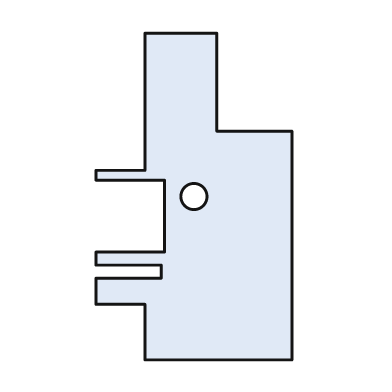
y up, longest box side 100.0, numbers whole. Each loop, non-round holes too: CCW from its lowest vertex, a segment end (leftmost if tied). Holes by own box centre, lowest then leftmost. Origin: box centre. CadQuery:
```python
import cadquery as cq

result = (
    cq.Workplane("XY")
    .moveTo(-15.0, -50.0)
    .lineTo(30.0, -50.0)
    .lineTo(30.0, 20.0)
    .lineTo(7.0, 20.0)
    .lineTo(7.0, 50.0)
    .lineTo(-15.0, 50.0)
    .lineTo(-15.0, 8.0)
    .lineTo(-30.0, 8.0)
    .lineTo(-30.0, 5.0)
    .lineTo(-9.0, 5.0)
    .lineTo(-9.0, -17.0)
    .lineTo(-30.0, -17.0)
    .lineTo(-30.0, -21.0)
    .lineTo(-10.0, -21.0)
    .lineTo(-10.0, -25.0)
    .lineTo(-30.0, -25.0)
    .lineTo(-30.0, -33.0)
    .lineTo(-15.0, -33.0)
    .close()
    .moveTo(0.0, 0.0)
    .circle(4.0)
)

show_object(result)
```